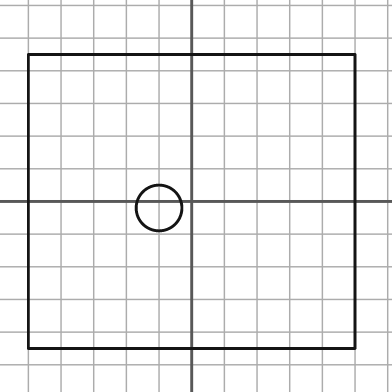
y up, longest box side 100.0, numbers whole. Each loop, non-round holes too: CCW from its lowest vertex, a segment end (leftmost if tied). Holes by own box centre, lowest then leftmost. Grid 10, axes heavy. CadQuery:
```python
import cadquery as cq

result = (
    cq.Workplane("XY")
    .moveTo(-50.0, -45.0)
    .lineTo(50.0, -45.0)
    .lineTo(50.0, 45.0)
    .lineTo(-50.0, 45.0)
    .close()
    .moveTo(-10.0, -2.0)
    .circle(7.0)
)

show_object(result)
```